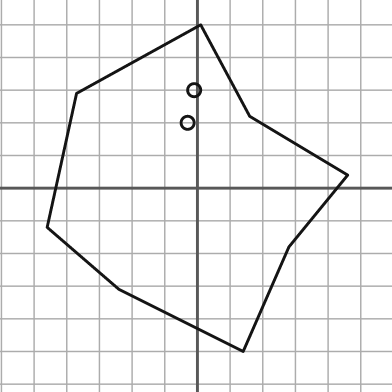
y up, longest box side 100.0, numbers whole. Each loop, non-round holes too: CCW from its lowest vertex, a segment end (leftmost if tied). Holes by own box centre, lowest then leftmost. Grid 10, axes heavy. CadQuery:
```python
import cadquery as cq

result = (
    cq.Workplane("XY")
    .moveTo(14.0, -50.0)
    .lineTo(28.0, -18.0)
    .lineTo(46.0, 4.0)
    .lineTo(16.0, 22.0)
    .lineTo(1.0, 50.0)
    .lineTo(-37.0, 29.0)
    .lineTo(-46.0, -12.0)
    .lineTo(-24.0, -31.0)
    .close()
    .moveTo(-3.0, 20.0)
    .circle(2.0)
    .moveTo(-1.0, 30.0)
    .circle(2.0)
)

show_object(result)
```